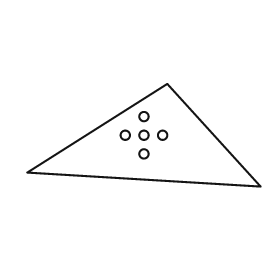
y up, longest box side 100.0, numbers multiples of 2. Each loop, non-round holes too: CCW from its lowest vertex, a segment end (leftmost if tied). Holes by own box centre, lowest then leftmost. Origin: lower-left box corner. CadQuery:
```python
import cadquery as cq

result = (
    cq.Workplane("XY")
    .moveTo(100.0, 0.0)
    .lineTo(60.0, 44.0)
    .lineTo(0.0, 6.0)
    .close()
    .moveTo(50.0, 14.0)
    .circle(2.0)
    .moveTo(42.0, 22.0)
    .circle(2.0)
    .moveTo(50.0, 22.0)
    .circle(2.0)
    .moveTo(58.0, 22.0)
    .circle(2.0)
    .moveTo(50.0, 30.0)
    .circle(2.0)
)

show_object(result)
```